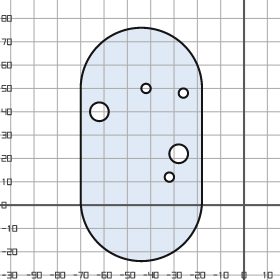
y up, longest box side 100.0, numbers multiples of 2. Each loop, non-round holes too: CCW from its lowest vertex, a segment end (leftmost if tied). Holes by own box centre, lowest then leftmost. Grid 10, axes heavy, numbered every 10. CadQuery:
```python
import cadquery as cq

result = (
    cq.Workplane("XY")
    .moveTo(-70.0, 2.0)
    .threePointArc((-44.0, -24.0), (-18.0, 2.0))
    .lineTo(-18.0, 50.0)
    .threePointArc((-44.0, 76.0), (-70.0, 50.0))
    .close()
    .moveTo(-32.0, 12.0)
    .circle(2.0)
    .moveTo(-28.0, 22.0)
    .circle(4.0)
    .moveTo(-62.0, 40.0)
    .circle(4.0)
    .moveTo(-26.0, 48.0)
    .circle(2.0)
    .moveTo(-42.0, 50.0)
    .circle(2.0)
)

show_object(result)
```